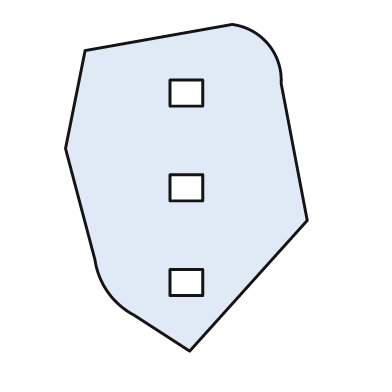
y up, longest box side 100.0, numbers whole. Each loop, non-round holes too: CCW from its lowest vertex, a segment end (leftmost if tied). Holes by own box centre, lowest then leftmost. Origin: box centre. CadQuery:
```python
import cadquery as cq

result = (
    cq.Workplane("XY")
    .moveTo(1.0, -50.0)
    .lineTo(37.0, -10.0)
    .lineTo(29.0, 32.0)
    .threePointArc((25.0, 44.0), (14.0, 50.0))
    .lineTo(-31.0, 42.0)
    .lineTo(-37.0, 12.0)
    .lineTo(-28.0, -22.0)
    .threePointArc((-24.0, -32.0), (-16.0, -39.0))
    .close()
    .moveTo(-5.0, -33.0)
    .lineTo(5.0, -33.0)
    .lineTo(5.0, -25.0)
    .lineTo(-5.0, -25.0)
    .close()
    .moveTo(-5.0, -4.0)
    .lineTo(5.0, -4.0)
    .lineTo(5.0, 4.0)
    .lineTo(-5.0, 4.0)
    .close()
    .moveTo(-5.0, 25.0)
    .lineTo(5.0, 25.0)
    .lineTo(5.0, 33.0)
    .lineTo(-5.0, 33.0)
    .close()
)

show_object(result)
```